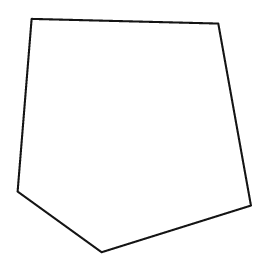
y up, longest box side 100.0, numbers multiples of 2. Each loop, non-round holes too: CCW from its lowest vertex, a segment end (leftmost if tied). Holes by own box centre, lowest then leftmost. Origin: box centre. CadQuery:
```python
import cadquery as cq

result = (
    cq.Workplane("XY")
    .moveTo(-14.0, -50.0)
    .lineTo(50.0, -30.0)
    .lineTo(36.0, 48.0)
    .lineTo(-44.0, 50.0)
    .lineTo(-50.0, -24.0)
    .close()
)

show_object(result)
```